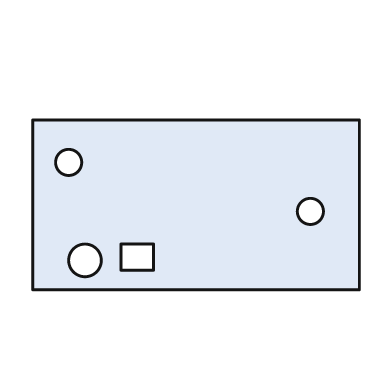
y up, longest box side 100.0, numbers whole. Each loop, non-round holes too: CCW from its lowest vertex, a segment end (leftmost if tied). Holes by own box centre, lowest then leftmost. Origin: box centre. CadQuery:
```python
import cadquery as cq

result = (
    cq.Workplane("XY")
    .moveTo(-50.0, -26.0)
    .lineTo(50.0, -26.0)
    .lineTo(50.0, 26.0)
    .lineTo(-50.0, 26.0)
    .close()
    .moveTo(-34.0, -17.0)
    .circle(5.0)
    .moveTo(-23.0, -20.0)
    .lineTo(-13.0, -20.0)
    .lineTo(-13.0, -12.0)
    .lineTo(-23.0, -12.0)
    .close()
    .moveTo(35.0, -2.0)
    .circle(4.0)
    .moveTo(-39.0, 13.0)
    .circle(4.0)
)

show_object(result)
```